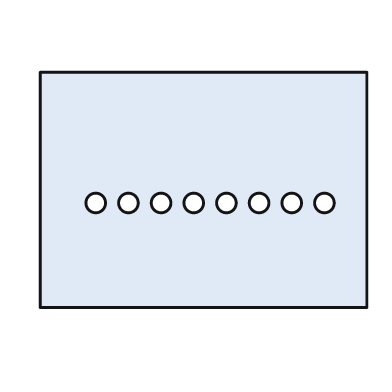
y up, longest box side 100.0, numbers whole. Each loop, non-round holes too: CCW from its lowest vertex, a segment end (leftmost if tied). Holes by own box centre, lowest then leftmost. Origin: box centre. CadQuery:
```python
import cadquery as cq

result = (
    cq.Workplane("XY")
    .moveTo(-50.0, -36.0)
    .lineTo(50.0, -36.0)
    .lineTo(50.0, 36.0)
    .lineTo(-50.0, 36.0)
    .close()
    .moveTo(-33.0, -4.0)
    .circle(3.0)
    .moveTo(-23.0, -4.0)
    .circle(3.0)
    .moveTo(-13.0, -4.0)
    .circle(3.0)
    .moveTo(-3.0, -4.0)
    .circle(3.0)
    .moveTo(7.0, -4.0)
    .circle(3.0)
    .moveTo(17.0, -4.0)
    .circle(3.0)
    .moveTo(27.0, -4.0)
    .circle(3.0)
    .moveTo(37.0, -4.0)
    .circle(3.0)
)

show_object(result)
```